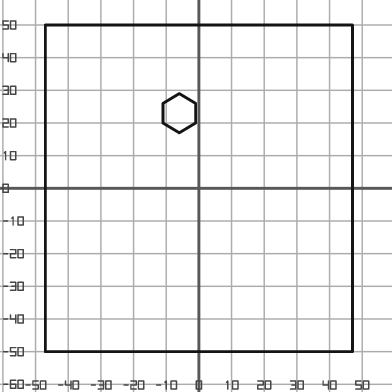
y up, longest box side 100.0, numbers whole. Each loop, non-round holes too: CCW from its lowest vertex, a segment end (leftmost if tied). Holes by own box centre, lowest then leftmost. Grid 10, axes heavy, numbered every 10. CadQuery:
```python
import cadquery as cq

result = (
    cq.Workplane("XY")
    .moveTo(-47.0, -50.0)
    .lineTo(47.0, -50.0)
    .lineTo(47.0, 50.0)
    .lineTo(-47.0, 50.0)
    .close()
    .moveTo(-6.0, 17.0)
    .lineTo(-1.0, 20.0)
    .lineTo(-1.0, 26.0)
    .lineTo(-6.0, 29.0)
    .lineTo(-11.0, 26.0)
    .lineTo(-11.0, 20.0)
    .close()
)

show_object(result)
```